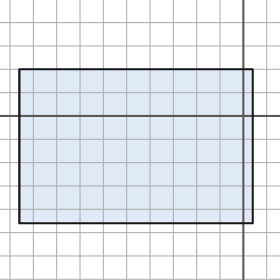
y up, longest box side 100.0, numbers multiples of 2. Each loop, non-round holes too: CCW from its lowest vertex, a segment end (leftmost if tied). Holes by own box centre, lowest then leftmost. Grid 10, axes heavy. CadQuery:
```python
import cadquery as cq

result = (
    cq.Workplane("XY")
    .moveTo(-96.0, -46.0)
    .lineTo(4.0, -46.0)
    .lineTo(4.0, 20.0)
    .lineTo(-96.0, 20.0)
    .close()
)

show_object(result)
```